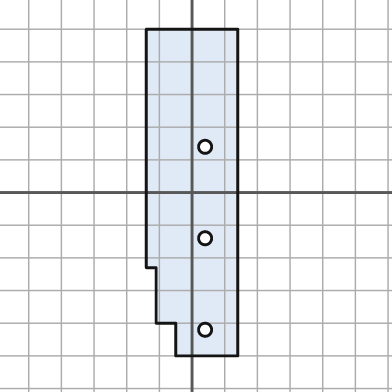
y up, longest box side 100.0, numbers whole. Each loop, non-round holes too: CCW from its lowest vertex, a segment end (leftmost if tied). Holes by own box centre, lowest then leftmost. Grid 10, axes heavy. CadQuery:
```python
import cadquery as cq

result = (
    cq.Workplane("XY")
    .moveTo(-5.0, -50.0)
    .lineTo(14.0, -50.0)
    .lineTo(14.0, 50.0)
    .lineTo(-14.0, 50.0)
    .lineTo(-14.0, -23.0)
    .lineTo(-11.0, -23.0)
    .lineTo(-11.0, -40.0)
    .lineTo(-5.0, -40.0)
    .close()
    .moveTo(4.0, -42.0)
    .circle(2.0)
    .moveTo(4.0, -14.0)
    .circle(2.0)
    .moveTo(4.0, 14.0)
    .circle(2.0)
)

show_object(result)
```